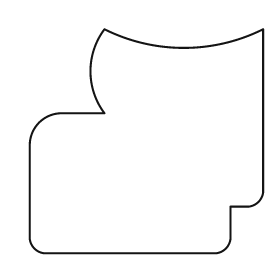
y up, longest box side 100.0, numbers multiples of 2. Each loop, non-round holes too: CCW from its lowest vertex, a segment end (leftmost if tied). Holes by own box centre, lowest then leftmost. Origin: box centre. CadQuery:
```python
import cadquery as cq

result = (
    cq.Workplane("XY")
    .moveTo(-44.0, -48.0)
    .lineTo(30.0, -48.0)
    .threePointArc((34.0, -46.0), (36.0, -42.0))
    .lineTo(36.0, -28.0)
    .lineTo(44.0, -28.0)
    .threePointArc((48.0, -26.0), (50.0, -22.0))
    .lineTo(50.0, 48.0)
    .threePointArc((16.0, 40.0), (-18.0, 48.0))
    .threePointArc((-24.0, 30.0), (-18.0, 12.0))
    .lineTo(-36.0, 12.0)
    .threePointArc((-46.0, 8.0), (-50.0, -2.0))
    .lineTo(-50.0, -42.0)
    .threePointArc((-48.0, -46.0), (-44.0, -48.0))
    .close()
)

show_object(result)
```